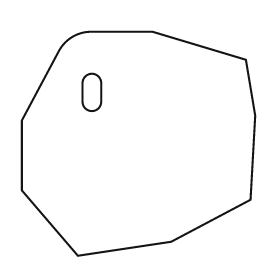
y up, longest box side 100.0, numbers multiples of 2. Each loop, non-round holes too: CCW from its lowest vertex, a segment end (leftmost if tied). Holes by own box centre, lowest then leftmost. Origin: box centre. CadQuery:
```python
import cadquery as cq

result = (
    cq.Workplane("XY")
    .moveTo(-26.0, -48.0)
    .lineTo(14.0, -42.0)
    .lineTo(48.0, -24.0)
    .lineTo(50.0, 12.0)
    .lineTo(46.0, 36.0)
    .lineTo(6.0, 48.0)
    .lineTo(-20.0, 48.0)
    .threePointArc((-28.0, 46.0), (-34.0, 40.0))
    .lineTo(-50.0, 10.0)
    .lineTo(-50.0, -20.0)
    .close()
    .moveTo(-24.0, 18.0)
    .threePointArc((-20.0, 14.0), (-16.0, 18.0))
    .lineTo(-16.0, 26.0)
    .threePointArc((-20.0, 30.0), (-24.0, 26.0))
    .close()
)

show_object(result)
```